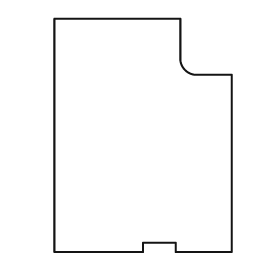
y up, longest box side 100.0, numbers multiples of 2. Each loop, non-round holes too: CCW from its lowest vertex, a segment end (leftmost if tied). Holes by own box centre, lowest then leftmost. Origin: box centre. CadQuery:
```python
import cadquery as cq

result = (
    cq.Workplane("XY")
    .moveTo(-38.0, -50.0)
    .lineTo(0.0, -50.0)
    .lineTo(0.0, -46.0)
    .lineTo(14.0, -46.0)
    .lineTo(14.0, -50.0)
    .lineTo(38.0, -50.0)
    .lineTo(38.0, 26.0)
    .lineTo(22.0, 26.0)
    .threePointArc((18.0, 28.0), (16.0, 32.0))
    .lineTo(16.0, 50.0)
    .lineTo(-38.0, 50.0)
    .close()
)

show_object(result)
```